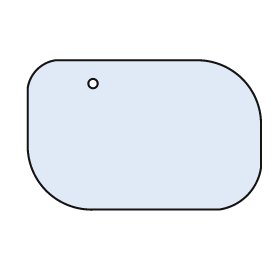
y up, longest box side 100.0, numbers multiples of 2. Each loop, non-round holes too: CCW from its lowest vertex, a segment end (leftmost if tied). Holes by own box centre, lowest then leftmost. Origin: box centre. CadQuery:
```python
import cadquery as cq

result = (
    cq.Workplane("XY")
    .moveTo(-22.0, -32.0)
    .lineTo(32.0, -32.0)
    .threePointArc((44.0, -26.0), (50.0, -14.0))
    .lineTo(50.0, 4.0)
    .threePointArc((42.0, 24.0), (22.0, 32.0))
    .lineTo(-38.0, 32.0)
    .threePointArc((-46.0, 28.0), (-50.0, 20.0))
    .lineTo(-50.0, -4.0)
    .threePointArc((-42.0, -24.0), (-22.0, -32.0))
    .close()
    .moveTo(-22.0, 22.0)
    .circle(2.0)
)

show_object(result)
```